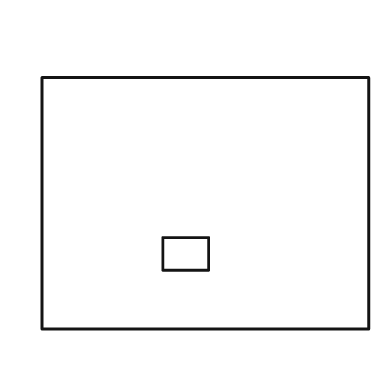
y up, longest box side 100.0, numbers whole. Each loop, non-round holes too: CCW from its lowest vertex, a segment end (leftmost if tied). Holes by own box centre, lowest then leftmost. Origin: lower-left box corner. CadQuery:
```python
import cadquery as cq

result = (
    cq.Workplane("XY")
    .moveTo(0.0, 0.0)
    .lineTo(100.0, 0.0)
    .lineTo(100.0, 77.0)
    .lineTo(0.0, 77.0)
    .close()
    .moveTo(37.0, 18.0)
    .lineTo(51.0, 18.0)
    .lineTo(51.0, 28.0)
    .lineTo(37.0, 28.0)
    .close()
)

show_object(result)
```